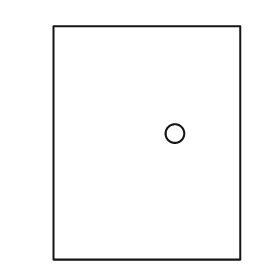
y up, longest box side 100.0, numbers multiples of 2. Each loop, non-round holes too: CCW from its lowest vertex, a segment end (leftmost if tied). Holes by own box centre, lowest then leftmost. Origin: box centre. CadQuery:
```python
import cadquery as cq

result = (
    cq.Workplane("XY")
    .moveTo(-40.0, -50.0)
    .lineTo(40.0, -50.0)
    .lineTo(40.0, 50.0)
    .lineTo(-40.0, 50.0)
    .close()
    .moveTo(12.0, 4.0)
    .circle(4.0)
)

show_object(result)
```